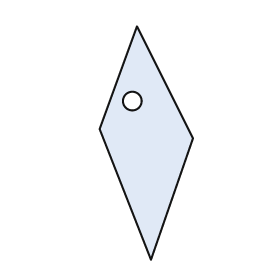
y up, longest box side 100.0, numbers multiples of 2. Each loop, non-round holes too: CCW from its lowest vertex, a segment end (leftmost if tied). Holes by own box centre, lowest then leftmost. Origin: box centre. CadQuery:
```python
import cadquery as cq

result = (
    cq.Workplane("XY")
    .moveTo(2.0, -50.0)
    .lineTo(20.0, 2.0)
    .lineTo(-4.0, 50.0)
    .lineTo(-20.0, 6.0)
    .close()
    .moveTo(-6.0, 18.0)
    .circle(4.0)
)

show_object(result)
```